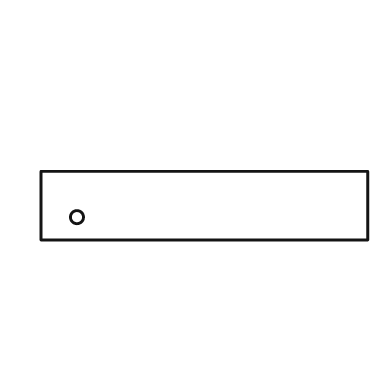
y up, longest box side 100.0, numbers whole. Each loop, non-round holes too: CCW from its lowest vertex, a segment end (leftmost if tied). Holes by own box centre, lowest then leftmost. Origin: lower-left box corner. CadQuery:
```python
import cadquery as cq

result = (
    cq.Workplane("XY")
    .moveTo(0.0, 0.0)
    .lineTo(100.0, 0.0)
    .lineTo(100.0, 21.0)
    .lineTo(0.0, 21.0)
    .close()
    .moveTo(11.0, 7.0)
    .circle(2.0)
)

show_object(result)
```